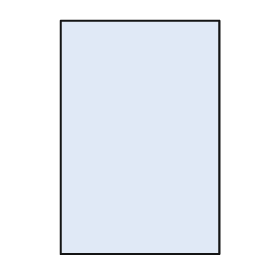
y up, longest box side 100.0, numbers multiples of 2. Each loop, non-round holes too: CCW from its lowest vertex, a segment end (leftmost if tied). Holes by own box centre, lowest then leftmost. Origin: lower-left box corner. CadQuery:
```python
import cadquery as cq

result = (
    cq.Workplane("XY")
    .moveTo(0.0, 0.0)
    .lineTo(68.0, 0.0)
    .lineTo(68.0, 100.0)
    .lineTo(0.0, 100.0)
    .close()
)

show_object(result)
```